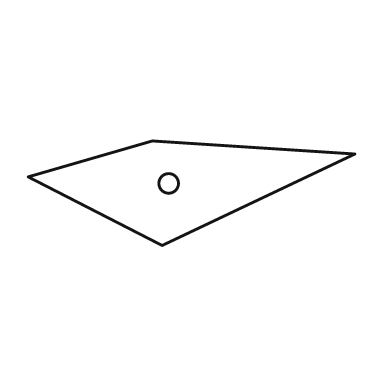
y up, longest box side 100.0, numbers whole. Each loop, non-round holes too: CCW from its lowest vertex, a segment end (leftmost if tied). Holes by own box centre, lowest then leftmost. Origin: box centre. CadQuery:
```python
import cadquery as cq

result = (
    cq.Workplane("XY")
    .moveTo(-9.0, -16.0)
    .lineTo(50.0, 12.0)
    .lineTo(-12.0, 16.0)
    .lineTo(-50.0, 5.0)
    .close()
    .moveTo(-7.0, 3.0)
    .circle(3.0)
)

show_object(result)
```